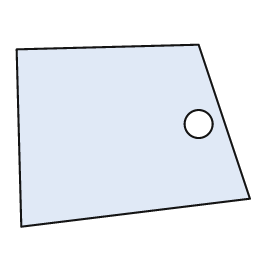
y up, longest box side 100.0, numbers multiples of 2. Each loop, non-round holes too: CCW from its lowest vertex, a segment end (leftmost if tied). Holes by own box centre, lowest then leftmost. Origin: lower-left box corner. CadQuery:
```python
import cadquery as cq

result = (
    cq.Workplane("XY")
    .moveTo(2.0, 0.0)
    .lineTo(100.0, 12.0)
    .lineTo(78.0, 78.0)
    .lineTo(0.0, 76.0)
    .close()
    .moveTo(78.0, 44.0)
    .circle(6.0)
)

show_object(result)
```